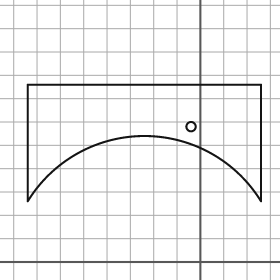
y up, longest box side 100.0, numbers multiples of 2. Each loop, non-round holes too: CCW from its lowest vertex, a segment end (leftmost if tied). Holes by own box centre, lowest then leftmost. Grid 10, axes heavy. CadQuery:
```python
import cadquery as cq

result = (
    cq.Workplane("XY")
    .moveTo(-74.0, 26.0)
    .threePointArc((-24.0, 54.0), (26.0, 26.0))
    .lineTo(26.0, 76.0)
    .lineTo(-74.0, 76.0)
    .close()
    .moveTo(-4.0, 58.0)
    .circle(2.0)
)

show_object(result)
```